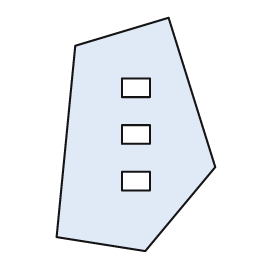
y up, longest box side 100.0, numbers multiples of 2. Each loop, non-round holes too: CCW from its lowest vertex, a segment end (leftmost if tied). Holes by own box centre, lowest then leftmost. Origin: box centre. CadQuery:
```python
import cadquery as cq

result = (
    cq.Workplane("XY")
    .moveTo(4.0, -50.0)
    .lineTo(34.0, -14.0)
    .lineTo(14.0, 50.0)
    .lineTo(-26.0, 38.0)
    .lineTo(-34.0, -44.0)
    .close()
    .moveTo(-6.0, -24.0)
    .lineTo(6.0, -24.0)
    .lineTo(6.0, -16.0)
    .lineTo(-6.0, -16.0)
    .close()
    .moveTo(-6.0, -4.0)
    .lineTo(6.0, -4.0)
    .lineTo(6.0, 4.0)
    .lineTo(-6.0, 4.0)
    .close()
    .moveTo(-6.0, 16.0)
    .lineTo(6.0, 16.0)
    .lineTo(6.0, 24.0)
    .lineTo(-6.0, 24.0)
    .close()
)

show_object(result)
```